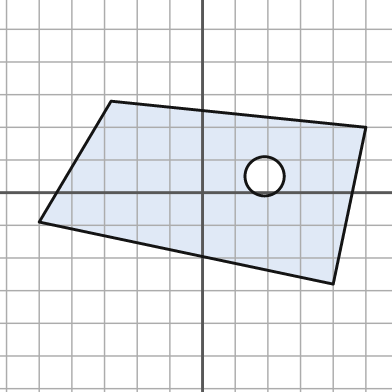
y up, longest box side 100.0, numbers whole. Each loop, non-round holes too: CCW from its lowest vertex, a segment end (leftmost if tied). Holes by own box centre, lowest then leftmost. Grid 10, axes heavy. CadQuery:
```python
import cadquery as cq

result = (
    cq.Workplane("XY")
    .moveTo(40.0, -28.0)
    .lineTo(50.0, 20.0)
    .lineTo(-28.0, 28.0)
    .lineTo(-50.0, -9.0)
    .close()
    .moveTo(19.0, 5.0)
    .circle(6.0)
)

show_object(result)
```